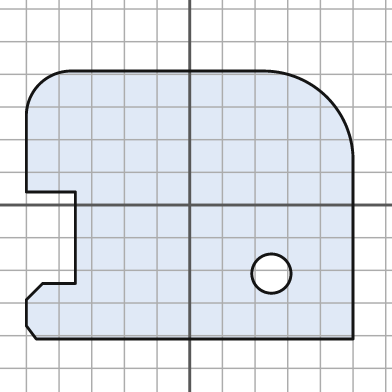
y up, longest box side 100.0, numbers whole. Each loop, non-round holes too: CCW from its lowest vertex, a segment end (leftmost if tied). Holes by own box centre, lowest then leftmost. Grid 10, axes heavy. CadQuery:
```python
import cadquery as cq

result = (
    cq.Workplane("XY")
    .moveTo(-47.0, -41.0)
    .lineTo(50.0, -41.0)
    .lineTo(50.0, 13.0)
    .threePointArc((42.0, 33.0), (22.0, 41.0))
    .lineTo(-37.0, 41.0)
    .threePointArc((-46.0, 37.0), (-50.0, 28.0))
    .lineTo(-50.0, 4.0)
    .lineTo(-35.0, 4.0)
    .lineTo(-35.0, -24.0)
    .lineTo(-45.0, -24.0)
    .lineTo(-50.0, -29.0)
    .lineTo(-50.0, -37.0)
    .close()
    .moveTo(25.0, -21.0)
    .circle(6.0)
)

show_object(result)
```